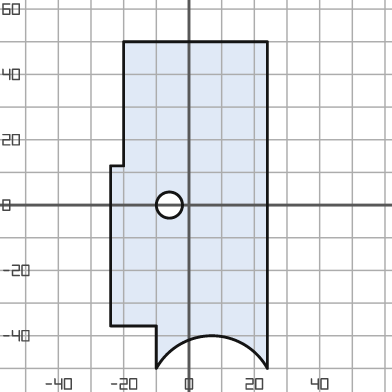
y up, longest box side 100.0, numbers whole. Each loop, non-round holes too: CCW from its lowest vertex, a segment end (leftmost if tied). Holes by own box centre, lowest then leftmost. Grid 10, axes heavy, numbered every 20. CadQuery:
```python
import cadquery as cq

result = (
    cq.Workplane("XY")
    .moveTo(-10.0, -50.0)
    .threePointArc((7.0, -40.0), (24.0, -50.0))
    .lineTo(24.0, 50.0)
    .lineTo(-20.0, 50.0)
    .lineTo(-20.0, 12.0)
    .lineTo(-24.0, 12.0)
    .lineTo(-24.0, -37.0)
    .lineTo(-10.0, -37.0)
    .close()
    .moveTo(-6.0, 0.0)
    .circle(4.0)
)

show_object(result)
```